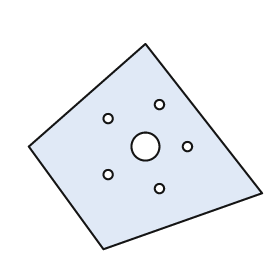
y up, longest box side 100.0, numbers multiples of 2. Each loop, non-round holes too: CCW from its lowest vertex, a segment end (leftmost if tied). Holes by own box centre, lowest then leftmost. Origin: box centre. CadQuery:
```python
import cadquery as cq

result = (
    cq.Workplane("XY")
    .moveTo(-18.0, -44.0)
    .lineTo(50.0, -20.0)
    .lineTo(0.0, 44.0)
    .lineTo(-50.0, 0.0)
    .close()
    .moveTo(6.0, -18.0)
    .circle(2.0)
    .moveTo(-16.0, -12.0)
    .circle(2.0)
    .moveTo(0.0, 0.0)
    .circle(6.0)
    .moveTo(18.0, 0.0)
    .circle(2.0)
    .moveTo(-16.0, 12.0)
    .circle(2.0)
    .moveTo(6.0, 18.0)
    .circle(2.0)
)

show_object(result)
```